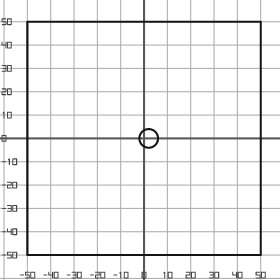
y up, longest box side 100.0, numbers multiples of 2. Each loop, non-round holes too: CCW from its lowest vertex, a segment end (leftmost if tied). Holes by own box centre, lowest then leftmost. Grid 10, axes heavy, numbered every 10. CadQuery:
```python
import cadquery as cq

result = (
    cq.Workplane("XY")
    .moveTo(-50.0, -50.0)
    .lineTo(50.0, -50.0)
    .lineTo(50.0, 50.0)
    .lineTo(-50.0, 50.0)
    .close()
    .moveTo(2.0, 0.0)
    .circle(4.0)
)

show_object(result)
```